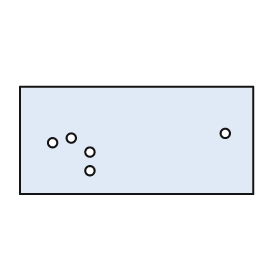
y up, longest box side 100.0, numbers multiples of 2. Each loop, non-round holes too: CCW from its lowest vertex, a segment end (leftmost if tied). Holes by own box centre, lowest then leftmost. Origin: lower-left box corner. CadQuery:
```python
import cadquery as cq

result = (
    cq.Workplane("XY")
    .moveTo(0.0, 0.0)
    .lineTo(100.0, 0.0)
    .lineTo(100.0, 46.0)
    .lineTo(0.0, 46.0)
    .close()
    .moveTo(30.0, 10.0)
    .circle(2.0)
    .moveTo(30.0, 18.0)
    .circle(2.0)
    .moveTo(14.0, 22.0)
    .circle(2.0)
    .moveTo(22.0, 24.0)
    .circle(2.0)
    .moveTo(88.0, 26.0)
    .circle(2.0)
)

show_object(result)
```